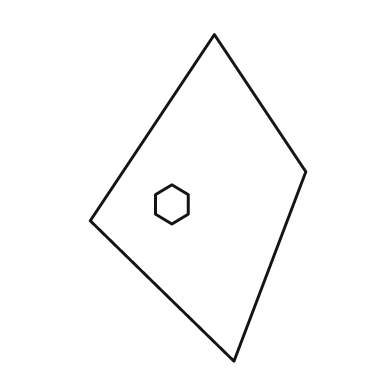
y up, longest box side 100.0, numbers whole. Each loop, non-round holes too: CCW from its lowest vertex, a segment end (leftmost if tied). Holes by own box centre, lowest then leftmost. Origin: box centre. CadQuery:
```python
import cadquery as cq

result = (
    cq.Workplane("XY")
    .moveTo(11.0, -50.0)
    .lineTo(33.0, 8.0)
    .lineTo(5.0, 50.0)
    .lineTo(-33.0, -7.0)
    .close()
    .moveTo(-8.0, -8.0)
    .lineTo(-3.0, -5.0)
    .lineTo(-3.0, 1.0)
    .lineTo(-8.0, 4.0)
    .lineTo(-13.0, 1.0)
    .lineTo(-13.0, -5.0)
    .close()
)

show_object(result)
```